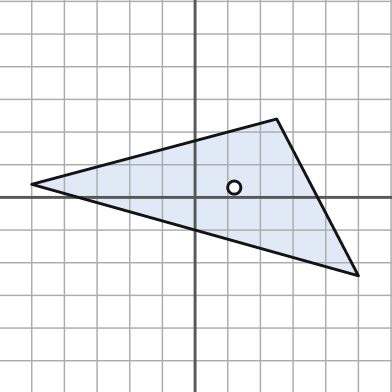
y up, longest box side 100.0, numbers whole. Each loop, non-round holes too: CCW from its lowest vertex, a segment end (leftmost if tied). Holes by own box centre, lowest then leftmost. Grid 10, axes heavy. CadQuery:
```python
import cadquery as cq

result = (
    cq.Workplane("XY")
    .moveTo(50.0, -24.0)
    .lineTo(25.0, 24.0)
    .lineTo(-50.0, 4.0)
    .close()
    .moveTo(12.0, 3.0)
    .circle(2.0)
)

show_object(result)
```